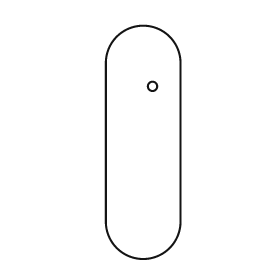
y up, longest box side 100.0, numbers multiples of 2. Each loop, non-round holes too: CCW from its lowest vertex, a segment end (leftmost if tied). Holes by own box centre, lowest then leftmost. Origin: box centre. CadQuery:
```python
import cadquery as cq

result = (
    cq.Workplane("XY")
    .moveTo(-16.0, -34.0)
    .threePointArc((0.0, -50.0), (16.0, -34.0))
    .lineTo(16.0, 34.0)
    .threePointArc((0.0, 50.0), (-16.0, 34.0))
    .close()
    .moveTo(4.0, 24.0)
    .circle(2.0)
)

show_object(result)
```